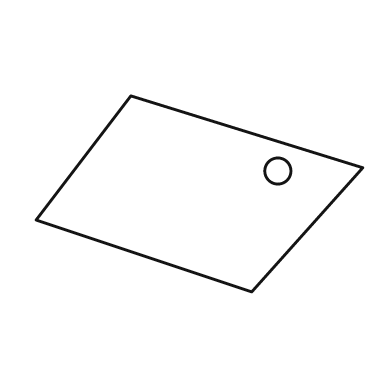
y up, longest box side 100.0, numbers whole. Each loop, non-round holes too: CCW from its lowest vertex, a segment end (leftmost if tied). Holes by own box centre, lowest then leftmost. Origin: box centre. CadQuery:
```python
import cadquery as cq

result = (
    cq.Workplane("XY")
    .moveTo(16.0, -30.0)
    .lineTo(50.0, 8.0)
    .lineTo(-21.0, 30.0)
    .lineTo(-50.0, -8.0)
    .close()
    .moveTo(24.0, 7.0)
    .circle(4.0)
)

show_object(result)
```